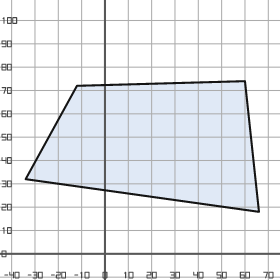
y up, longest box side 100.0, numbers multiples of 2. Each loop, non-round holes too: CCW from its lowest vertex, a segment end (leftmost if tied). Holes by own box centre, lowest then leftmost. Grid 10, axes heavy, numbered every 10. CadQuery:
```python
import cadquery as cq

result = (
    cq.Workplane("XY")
    .moveTo(66.0, 18.0)
    .lineTo(60.0, 74.0)
    .lineTo(-12.0, 72.0)
    .lineTo(-34.0, 32.0)
    .close()
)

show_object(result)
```